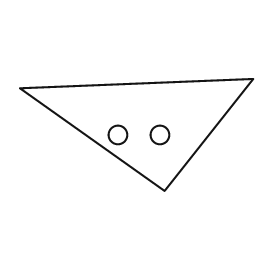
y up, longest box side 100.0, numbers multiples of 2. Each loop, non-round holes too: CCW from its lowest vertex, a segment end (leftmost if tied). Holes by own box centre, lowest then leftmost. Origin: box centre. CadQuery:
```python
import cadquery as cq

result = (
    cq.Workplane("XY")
    .moveTo(12.0, -24.0)
    .lineTo(50.0, 24.0)
    .lineTo(-50.0, 20.0)
    .close()
    .moveTo(-8.0, 0.0)
    .circle(4.0)
    .moveTo(10.0, 0.0)
    .circle(4.0)
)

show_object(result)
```